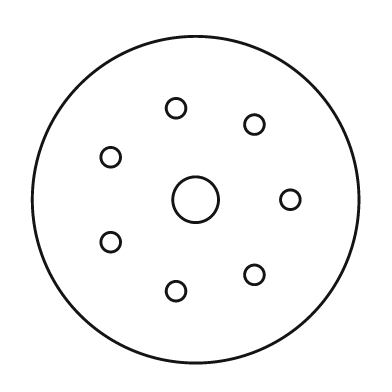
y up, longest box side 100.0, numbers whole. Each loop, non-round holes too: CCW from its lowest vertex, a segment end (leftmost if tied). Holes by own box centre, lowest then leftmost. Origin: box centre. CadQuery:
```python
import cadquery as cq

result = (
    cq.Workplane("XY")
    .moveTo(0.0, 0.0)
    .circle(50.0)
    .moveTo(-6.0, -28.0)
    .circle(3.0)
    .moveTo(18.0, -23.0)
    .circle(3.0)
    .moveTo(-26.0, -13.0)
    .circle(3.0)
    .moveTo(0.0, 0.0)
    .circle(7.0)
    .moveTo(29.0, 0.0)
    .circle(3.0)
    .moveTo(-26.0, 13.0)
    .circle(3.0)
    .moveTo(18.0, 23.0)
    .circle(3.0)
    .moveTo(-6.0, 28.0)
    .circle(3.0)
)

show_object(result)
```